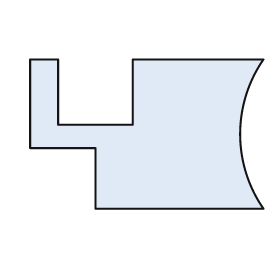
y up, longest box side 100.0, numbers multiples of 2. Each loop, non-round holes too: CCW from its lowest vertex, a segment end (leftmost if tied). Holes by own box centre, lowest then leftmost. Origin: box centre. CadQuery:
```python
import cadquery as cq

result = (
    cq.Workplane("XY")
    .moveTo(-22.0, -32.0)
    .lineTo(50.0, -32.0)
    .threePointArc((40.0, 0.0), (50.0, 32.0))
    .lineTo(-6.0, 32.0)
    .lineTo(-6.0, 4.0)
    .lineTo(-38.0, 4.0)
    .lineTo(-38.0, 32.0)
    .lineTo(-50.0, 32.0)
    .lineTo(-50.0, -6.0)
    .lineTo(-22.0, -6.0)
    .close()
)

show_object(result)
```